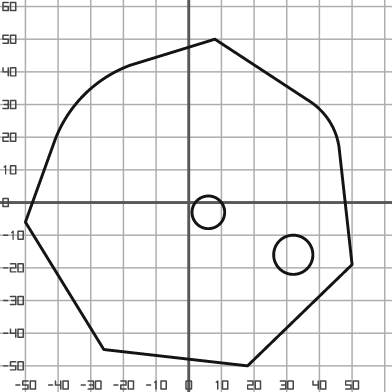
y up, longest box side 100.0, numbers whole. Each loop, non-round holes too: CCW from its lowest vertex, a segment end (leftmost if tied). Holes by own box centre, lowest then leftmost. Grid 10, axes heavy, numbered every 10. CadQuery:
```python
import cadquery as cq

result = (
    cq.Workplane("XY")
    .moveTo(18.0, -50.0)
    .lineTo(50.0, -19.0)
    .lineTo(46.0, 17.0)
    .threePointArc((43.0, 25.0), (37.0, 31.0))
    .lineTo(8.0, 50.0)
    .lineTo(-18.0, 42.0)
    .threePointArc((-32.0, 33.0), (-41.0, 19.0))
    .lineTo(-50.0, -6.0)
    .lineTo(-26.0, -45.0)
    .close()
    .moveTo(32.0, -16.0)
    .circle(6.0)
    .moveTo(6.0, -3.0)
    .circle(5.0)
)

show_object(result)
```